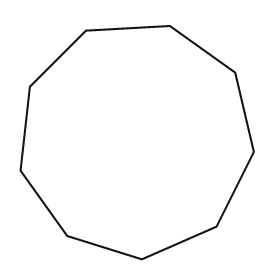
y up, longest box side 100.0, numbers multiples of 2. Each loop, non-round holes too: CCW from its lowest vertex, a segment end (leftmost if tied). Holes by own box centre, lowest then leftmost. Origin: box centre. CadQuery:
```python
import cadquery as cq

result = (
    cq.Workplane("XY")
    .moveTo(2.0, -50.0)
    .lineTo(34.0, -36.0)
    .lineTo(50.0, -4.0)
    .lineTo(42.0, 30.0)
    .lineTo(14.0, 50.0)
    .lineTo(-22.0, 48.0)
    .lineTo(-46.0, 24.0)
    .lineTo(-50.0, -12.0)
    .lineTo(-30.0, -40.0)
    .close()
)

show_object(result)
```